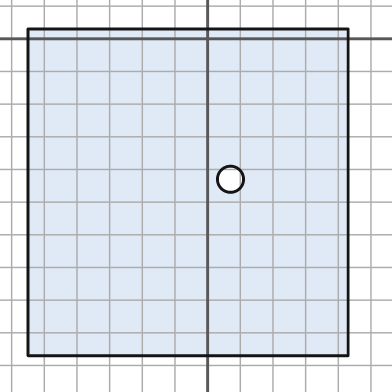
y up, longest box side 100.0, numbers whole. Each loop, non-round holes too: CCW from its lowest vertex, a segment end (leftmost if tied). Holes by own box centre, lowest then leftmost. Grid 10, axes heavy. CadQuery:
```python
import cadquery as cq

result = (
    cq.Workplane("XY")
    .moveTo(-55.0, -97.0)
    .lineTo(43.0, -97.0)
    .lineTo(43.0, 3.0)
    .lineTo(-55.0, 3.0)
    .close()
    .moveTo(7.0, -43.0)
    .circle(4.0)
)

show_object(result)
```